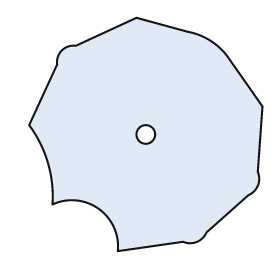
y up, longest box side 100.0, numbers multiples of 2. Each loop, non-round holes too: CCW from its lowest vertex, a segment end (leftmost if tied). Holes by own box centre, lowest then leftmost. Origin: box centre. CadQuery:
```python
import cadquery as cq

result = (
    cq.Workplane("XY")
    .moveTo(-12.0, -50.0)
    .lineTo(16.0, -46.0)
    .threePointArc((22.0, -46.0), (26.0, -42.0))
    .lineTo(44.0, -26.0)
    .threePointArc((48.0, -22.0), (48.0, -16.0))
    .lineTo(50.0, 12.0)
    .lineTo(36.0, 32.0)
    .threePointArc((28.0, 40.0), (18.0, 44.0))
    .lineTo(-4.0, 50.0)
    .lineTo(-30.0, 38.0)
    .threePointArc((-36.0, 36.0), (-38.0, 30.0))
    .lineTo(-50.0, 4.0)
    .threePointArc((-42.0, -12.0), (-40.0, -30.0))
    .threePointArc((-20.0, -32.0), (-12.0, -50.0))
    .close()
    .moveTo(0.0, 0.0)
    .circle(4.0)
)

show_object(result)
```